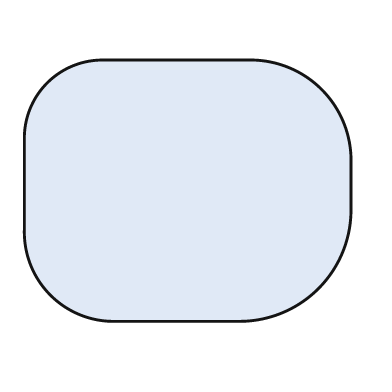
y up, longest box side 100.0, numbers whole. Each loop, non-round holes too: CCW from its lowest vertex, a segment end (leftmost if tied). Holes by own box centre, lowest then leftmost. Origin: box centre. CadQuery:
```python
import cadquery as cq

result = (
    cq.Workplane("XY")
    .moveTo(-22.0, -40.0)
    .lineTo(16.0, -40.0)
    .threePointArc((40.0, -30.0), (50.0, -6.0))
    .lineTo(50.0, 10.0)
    .threePointArc((41.0, 31.0), (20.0, 40.0))
    .lineTo(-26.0, 40.0)
    .threePointArc((-43.0, 33.0), (-50.0, 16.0))
    .lineTo(-50.0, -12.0)
    .threePointArc((-42.0, -32.0), (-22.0, -40.0))
    .close()
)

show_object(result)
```